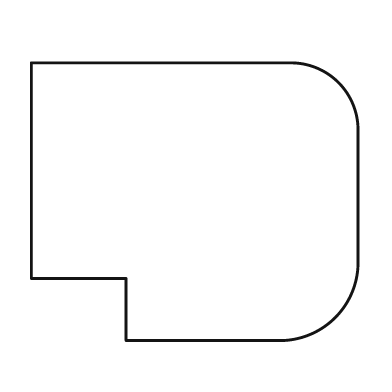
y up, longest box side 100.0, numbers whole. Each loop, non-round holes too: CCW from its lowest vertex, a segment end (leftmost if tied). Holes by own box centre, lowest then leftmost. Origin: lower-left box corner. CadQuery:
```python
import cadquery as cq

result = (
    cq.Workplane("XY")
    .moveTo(29.0, 0.0)
    .lineTo(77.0, 0.0)
    .threePointArc((93.0, 7.0), (100.0, 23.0))
    .lineTo(100.0, 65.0)
    .threePointArc((94.0, 79.0), (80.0, 85.0))
    .lineTo(0.0, 85.0)
    .lineTo(0.0, 19.0)
    .lineTo(29.0, 19.0)
    .close()
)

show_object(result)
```